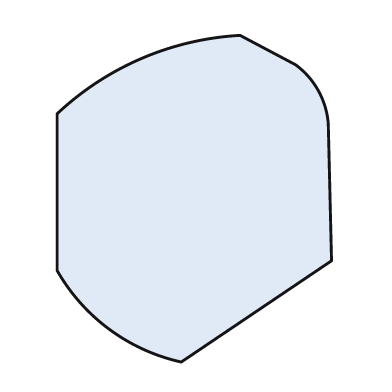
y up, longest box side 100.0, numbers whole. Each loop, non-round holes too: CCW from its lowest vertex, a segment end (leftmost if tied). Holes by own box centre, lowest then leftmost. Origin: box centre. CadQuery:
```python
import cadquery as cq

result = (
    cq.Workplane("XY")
    .moveTo(-4.0, -50.0)
    .lineTo(42.0, -19.0)
    .lineTo(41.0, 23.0)
    .threePointArc((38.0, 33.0), (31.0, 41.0))
    .lineTo(14.0, 50.0)
    .threePointArc((-16.0, 43.0), (-42.0, 26.0))
    .lineTo(-42.0, -22.0)
    .threePointArc((-26.0, -40.0), (-4.0, -50.0))
    .close()
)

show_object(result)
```